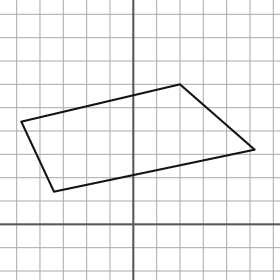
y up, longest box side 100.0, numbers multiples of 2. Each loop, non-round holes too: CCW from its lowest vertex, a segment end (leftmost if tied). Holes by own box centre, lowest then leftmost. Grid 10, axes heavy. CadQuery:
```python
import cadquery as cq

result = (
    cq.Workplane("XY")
    .moveTo(-34.0, 14.0)
    .lineTo(52.0, 32.0)
    .lineTo(20.0, 60.0)
    .lineTo(-48.0, 44.0)
    .close()
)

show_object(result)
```